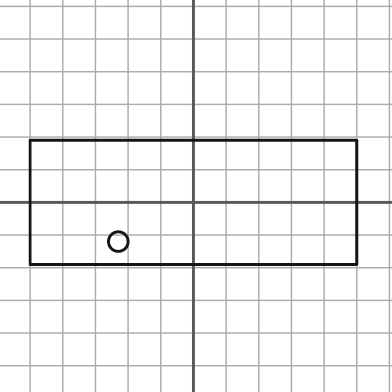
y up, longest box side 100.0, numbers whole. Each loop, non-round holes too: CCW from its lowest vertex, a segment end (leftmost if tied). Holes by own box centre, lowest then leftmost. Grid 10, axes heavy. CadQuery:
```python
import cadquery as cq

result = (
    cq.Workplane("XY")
    .moveTo(-50.0, -19.0)
    .lineTo(50.0, -19.0)
    .lineTo(50.0, 19.0)
    .lineTo(-50.0, 19.0)
    .close()
    .moveTo(-23.0, -12.0)
    .circle(3.0)
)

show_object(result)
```